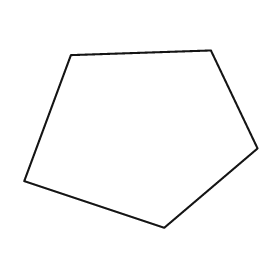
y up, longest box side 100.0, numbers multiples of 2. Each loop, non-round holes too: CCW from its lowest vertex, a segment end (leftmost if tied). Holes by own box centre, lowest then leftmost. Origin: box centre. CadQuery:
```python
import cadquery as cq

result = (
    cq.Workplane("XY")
    .moveTo(10.0, -38.0)
    .lineTo(50.0, -4.0)
    .lineTo(30.0, 38.0)
    .lineTo(-30.0, 36.0)
    .lineTo(-50.0, -18.0)
    .close()
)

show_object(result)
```